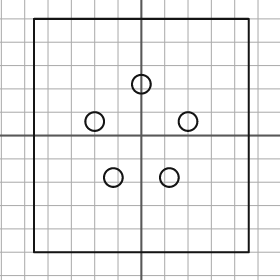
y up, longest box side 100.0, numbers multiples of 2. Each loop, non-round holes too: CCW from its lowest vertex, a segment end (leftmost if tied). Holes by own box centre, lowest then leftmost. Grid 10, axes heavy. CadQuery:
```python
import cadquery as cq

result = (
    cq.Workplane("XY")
    .moveTo(-46.0, -50.0)
    .lineTo(46.0, -50.0)
    .lineTo(46.0, 50.0)
    .lineTo(-46.0, 50.0)
    .close()
    .moveTo(-12.0, -18.0)
    .circle(4.0)
    .moveTo(12.0, -18.0)
    .circle(4.0)
    .moveTo(-20.0, 6.0)
    .circle(4.0)
    .moveTo(20.0, 6.0)
    .circle(4.0)
    .moveTo(0.0, 22.0)
    .circle(4.0)
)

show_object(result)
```